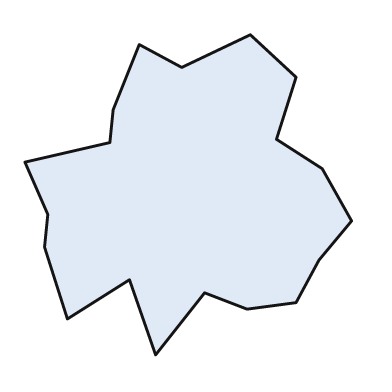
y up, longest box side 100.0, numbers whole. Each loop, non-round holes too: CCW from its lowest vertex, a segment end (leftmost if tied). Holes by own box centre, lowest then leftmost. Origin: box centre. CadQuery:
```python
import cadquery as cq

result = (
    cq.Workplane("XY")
    .moveTo(-10.0, -49.0)
    .lineTo(5.0, -30.0)
    .lineTo(18.0, -35.0)
    .lineTo(33.0, -33.0)
    .lineTo(40.0, -20.0)
    .lineTo(50.0, -8.0)
    .lineTo(41.0, 8.0)
    .lineTo(27.0, 17.0)
    .lineTo(33.0, 36.0)
    .lineTo(19.0, 49.0)
    .lineTo(-2.0, 39.0)
    .lineTo(-15.0, 46.0)
    .lineTo(-23.0, 26.0)
    .lineTo(-24.0, 16.0)
    .lineTo(-50.0, 10.0)
    .lineTo(-43.0, -6.0)
    .lineTo(-44.0, -16.0)
    .lineTo(-37.0, -38.0)
    .lineTo(-18.0, -26.0)
    .close()
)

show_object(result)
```